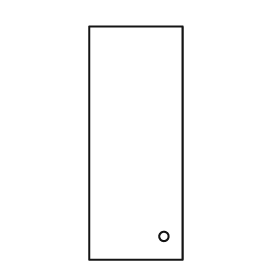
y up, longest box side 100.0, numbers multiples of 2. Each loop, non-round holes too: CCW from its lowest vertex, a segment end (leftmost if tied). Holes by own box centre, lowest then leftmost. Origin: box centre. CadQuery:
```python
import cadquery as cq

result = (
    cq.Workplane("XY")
    .moveTo(-20.0, -50.0)
    .lineTo(20.0, -50.0)
    .lineTo(20.0, 50.0)
    .lineTo(-20.0, 50.0)
    .close()
    .moveTo(12.0, -40.0)
    .circle(2.0)
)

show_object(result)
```